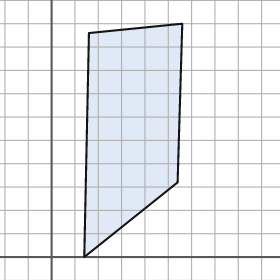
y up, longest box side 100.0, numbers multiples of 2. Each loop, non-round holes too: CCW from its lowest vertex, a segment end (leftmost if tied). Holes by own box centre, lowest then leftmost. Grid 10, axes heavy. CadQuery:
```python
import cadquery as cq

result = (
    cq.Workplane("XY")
    .moveTo(14.0, 0.0)
    .lineTo(54.0, 32.0)
    .lineTo(56.0, 100.0)
    .lineTo(16.0, 96.0)
    .close()
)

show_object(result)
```